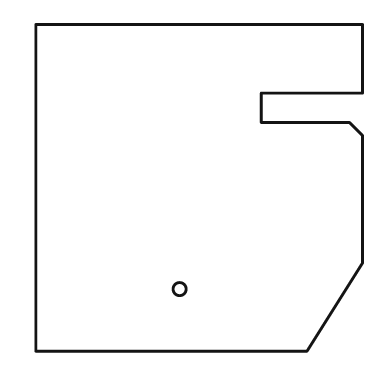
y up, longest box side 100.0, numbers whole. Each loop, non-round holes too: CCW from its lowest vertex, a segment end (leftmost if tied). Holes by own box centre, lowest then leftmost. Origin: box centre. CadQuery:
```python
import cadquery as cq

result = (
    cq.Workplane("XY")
    .moveTo(-50.0, -50.0)
    .lineTo(33.0, -50.0)
    .lineTo(50.0, -23.0)
    .lineTo(50.0, 16.0)
    .lineTo(46.0, 20.0)
    .lineTo(19.0, 20.0)
    .lineTo(19.0, 29.0)
    .lineTo(50.0, 29.0)
    .lineTo(50.0, 50.0)
    .lineTo(-50.0, 50.0)
    .close()
    .moveTo(-6.0, -31.0)
    .circle(2.0)
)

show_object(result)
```